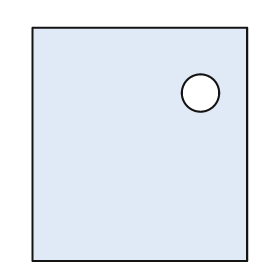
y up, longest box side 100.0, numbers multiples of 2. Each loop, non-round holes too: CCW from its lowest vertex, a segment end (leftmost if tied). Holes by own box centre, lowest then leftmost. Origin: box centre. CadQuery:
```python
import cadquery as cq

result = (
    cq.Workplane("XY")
    .moveTo(-46.0, -50.0)
    .lineTo(46.0, -50.0)
    .lineTo(46.0, 50.0)
    .lineTo(-46.0, 50.0)
    .close()
    .moveTo(26.0, 22.0)
    .circle(8.0)
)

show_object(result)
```